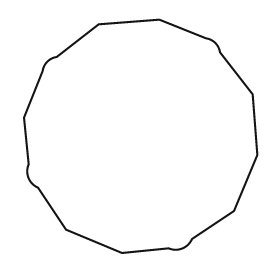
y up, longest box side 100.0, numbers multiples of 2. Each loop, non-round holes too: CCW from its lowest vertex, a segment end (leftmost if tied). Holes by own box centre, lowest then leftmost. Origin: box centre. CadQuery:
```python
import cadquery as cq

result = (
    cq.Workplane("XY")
    .moveTo(-8.0, -50.0)
    .lineTo(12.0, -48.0)
    .threePointArc((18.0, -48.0), (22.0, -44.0))
    .lineTo(40.0, -32.0)
    .lineTo(50.0, -8.0)
    .lineTo(48.0, 18.0)
    .lineTo(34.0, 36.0)
    .threePointArc((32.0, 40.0), (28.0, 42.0))
    .lineTo(8.0, 50.0)
    .lineTo(-18.0, 48.0)
    .lineTo(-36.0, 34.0)
    .threePointArc((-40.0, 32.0), (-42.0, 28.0))
    .lineTo(-50.0, 8.0)
    .lineTo(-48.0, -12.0)
    .threePointArc((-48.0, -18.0), (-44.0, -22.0))
    .lineTo(-32.0, -40.0)
    .close()
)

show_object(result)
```